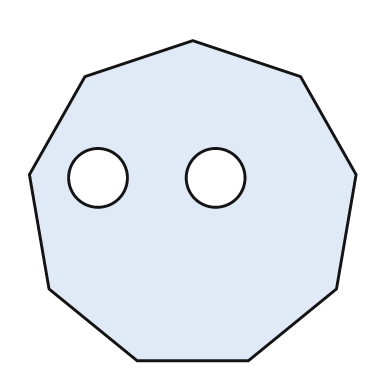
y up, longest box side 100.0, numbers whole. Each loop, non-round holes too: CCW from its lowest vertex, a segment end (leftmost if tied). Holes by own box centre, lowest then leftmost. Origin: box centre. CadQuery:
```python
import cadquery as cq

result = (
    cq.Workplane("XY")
    .moveTo(-17.0, -49.0)
    .lineTo(17.0, -49.0)
    .lineTo(44.0, -27.0)
    .lineTo(50.0, 8.0)
    .lineTo(33.0, 38.0)
    .lineTo(0.0, 49.0)
    .lineTo(-33.0, 38.0)
    .lineTo(-50.0, 8.0)
    .lineTo(-44.0, -27.0)
    .close()
    .moveTo(-29.0, 7.0)
    .circle(9.0)
    .moveTo(7.0, 7.0)
    .circle(9.0)
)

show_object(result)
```